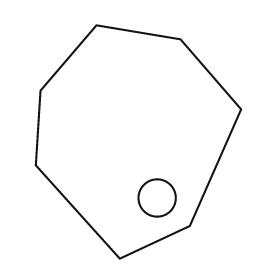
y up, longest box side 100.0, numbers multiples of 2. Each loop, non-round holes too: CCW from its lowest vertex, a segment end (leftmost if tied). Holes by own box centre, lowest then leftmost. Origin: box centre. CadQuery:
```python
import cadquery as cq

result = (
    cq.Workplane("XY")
    .moveTo(-8.0, -50.0)
    .lineTo(22.0, -36.0)
    .lineTo(44.0, 14.0)
    .lineTo(18.0, 44.0)
    .lineTo(-18.0, 50.0)
    .lineTo(-42.0, 22.0)
    .lineTo(-44.0, -10.0)
    .close()
    .moveTo(8.0, -24.0)
    .circle(8.0)
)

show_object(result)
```